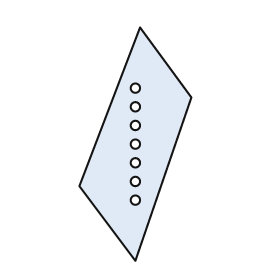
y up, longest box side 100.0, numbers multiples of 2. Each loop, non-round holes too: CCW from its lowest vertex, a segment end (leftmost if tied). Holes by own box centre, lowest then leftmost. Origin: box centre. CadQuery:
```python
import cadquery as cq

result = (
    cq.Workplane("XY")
    .moveTo(0.0, -50.0)
    .lineTo(24.0, 20.0)
    .lineTo(2.0, 50.0)
    .lineTo(-24.0, -18.0)
    .close()
    .moveTo(0.0, -24.0)
    .circle(2.0)
    .moveTo(0.0, -16.0)
    .circle(2.0)
    .moveTo(0.0, -8.0)
    .circle(2.0)
    .moveTo(0.0, 0.0)
    .circle(2.0)
    .moveTo(0.0, 8.0)
    .circle(2.0)
    .moveTo(0.0, 16.0)
    .circle(2.0)
    .moveTo(0.0, 24.0)
    .circle(2.0)
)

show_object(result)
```